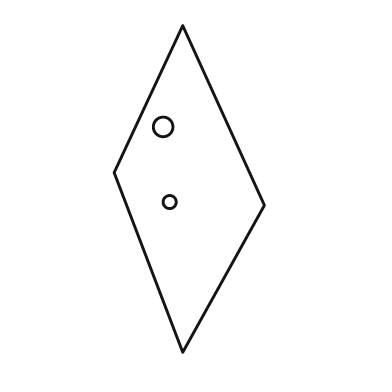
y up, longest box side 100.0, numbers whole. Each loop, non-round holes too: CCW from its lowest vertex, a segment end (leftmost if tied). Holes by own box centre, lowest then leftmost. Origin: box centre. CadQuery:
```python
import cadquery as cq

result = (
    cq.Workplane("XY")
    .moveTo(-2.0, -50.0)
    .lineTo(23.0, -5.0)
    .lineTo(-2.0, 50.0)
    .lineTo(-23.0, 5.0)
    .close()
    .moveTo(-6.0, -4.0)
    .circle(2.0)
    .moveTo(-8.0, 19.0)
    .circle(3.0)
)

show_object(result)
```